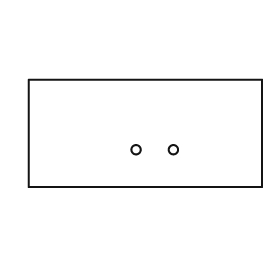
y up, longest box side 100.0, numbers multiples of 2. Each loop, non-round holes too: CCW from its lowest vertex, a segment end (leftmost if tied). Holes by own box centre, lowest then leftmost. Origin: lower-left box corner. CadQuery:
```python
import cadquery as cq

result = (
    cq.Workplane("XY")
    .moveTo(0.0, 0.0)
    .lineTo(100.0, 0.0)
    .lineTo(100.0, 46.0)
    .lineTo(0.0, 46.0)
    .close()
    .moveTo(46.0, 16.0)
    .circle(2.0)
    .moveTo(62.0, 16.0)
    .circle(2.0)
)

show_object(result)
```